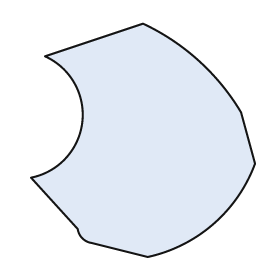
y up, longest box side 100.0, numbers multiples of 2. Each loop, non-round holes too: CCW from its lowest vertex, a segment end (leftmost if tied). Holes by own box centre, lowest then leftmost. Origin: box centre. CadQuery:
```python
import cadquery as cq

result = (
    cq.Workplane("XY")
    .moveTo(2.0, -50.0)
    .threePointArc((30.0, -36.0), (48.0, -10.0))
    .lineTo(42.0, 12.0)
    .threePointArc((24.0, 34.0), (0.0, 50.0))
    .lineTo(-42.0, 36.0)
    .threePointArc((-26.0, 8.0), (-48.0, -16.0))
    .lineTo(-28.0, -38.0)
    .threePointArc((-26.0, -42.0), (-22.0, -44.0))
    .close()
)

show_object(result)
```